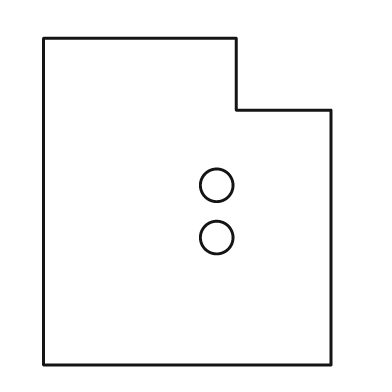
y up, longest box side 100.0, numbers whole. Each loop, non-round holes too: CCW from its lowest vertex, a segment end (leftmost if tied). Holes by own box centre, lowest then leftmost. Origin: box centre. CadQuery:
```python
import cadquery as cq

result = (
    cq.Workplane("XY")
    .moveTo(-44.0, -50.0)
    .lineTo(44.0, -50.0)
    .lineTo(44.0, 28.0)
    .lineTo(15.0, 28.0)
    .lineTo(15.0, 50.0)
    .lineTo(-44.0, 50.0)
    .close()
    .moveTo(9.0, -11.0)
    .circle(5.0)
    .moveTo(9.0, 5.0)
    .circle(5.0)
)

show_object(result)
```